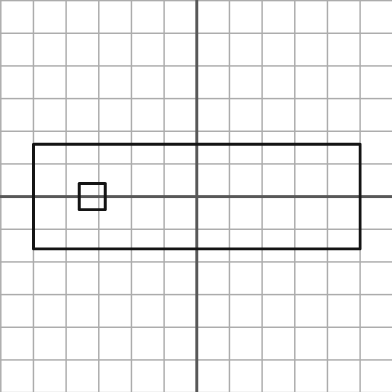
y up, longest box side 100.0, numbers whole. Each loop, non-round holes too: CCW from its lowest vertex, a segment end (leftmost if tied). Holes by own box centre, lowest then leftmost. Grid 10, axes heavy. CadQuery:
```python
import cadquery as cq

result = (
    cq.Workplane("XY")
    .moveTo(-50.0, -16.0)
    .lineTo(50.0, -16.0)
    .lineTo(50.0, 16.0)
    .lineTo(-50.0, 16.0)
    .close()
    .moveTo(-36.0, -4.0)
    .lineTo(-28.0, -4.0)
    .lineTo(-28.0, 4.0)
    .lineTo(-36.0, 4.0)
    .close()
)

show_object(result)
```